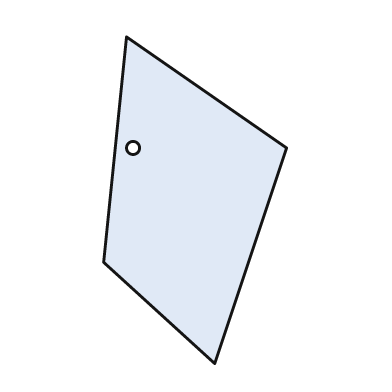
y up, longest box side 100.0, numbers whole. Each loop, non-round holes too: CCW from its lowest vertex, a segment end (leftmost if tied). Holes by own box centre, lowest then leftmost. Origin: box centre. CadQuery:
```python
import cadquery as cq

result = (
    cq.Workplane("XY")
    .moveTo(6.0, -50.0)
    .lineTo(28.0, 16.0)
    .lineTo(-21.0, 50.0)
    .lineTo(-28.0, -19.0)
    .close()
    .moveTo(-19.0, 16.0)
    .circle(2.0)
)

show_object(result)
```